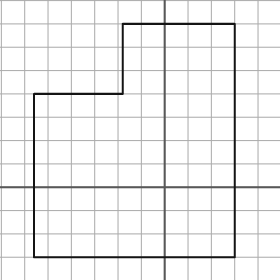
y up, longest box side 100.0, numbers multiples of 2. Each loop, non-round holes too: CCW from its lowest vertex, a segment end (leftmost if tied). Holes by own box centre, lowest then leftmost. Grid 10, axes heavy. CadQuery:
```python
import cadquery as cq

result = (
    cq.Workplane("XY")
    .moveTo(-56.0, -30.0)
    .lineTo(30.0, -30.0)
    .lineTo(30.0, 70.0)
    .lineTo(-18.0, 70.0)
    .lineTo(-18.0, 40.0)
    .lineTo(-56.0, 40.0)
    .close()
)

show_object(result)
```